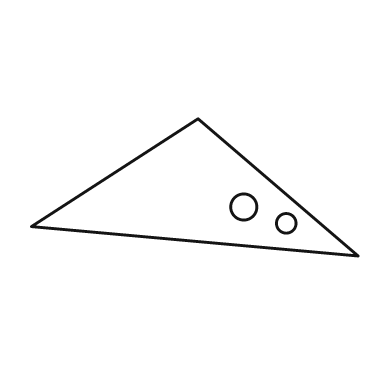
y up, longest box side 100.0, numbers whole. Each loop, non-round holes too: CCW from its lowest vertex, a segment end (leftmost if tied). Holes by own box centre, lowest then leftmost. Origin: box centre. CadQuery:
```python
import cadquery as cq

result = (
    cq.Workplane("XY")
    .moveTo(50.0, -21.0)
    .lineTo(1.0, 21.0)
    .lineTo(-50.0, -12.0)
    .close()
    .moveTo(28.0, -11.0)
    .circle(3.0)
    .moveTo(15.0, -6.0)
    .circle(4.0)
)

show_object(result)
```